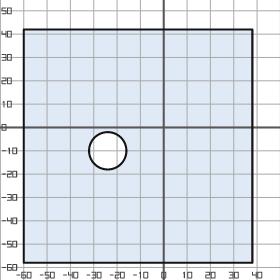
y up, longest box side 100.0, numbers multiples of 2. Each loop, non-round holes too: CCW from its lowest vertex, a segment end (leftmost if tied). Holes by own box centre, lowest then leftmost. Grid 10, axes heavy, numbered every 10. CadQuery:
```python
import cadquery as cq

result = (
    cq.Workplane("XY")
    .moveTo(-60.0, -58.0)
    .lineTo(38.0, -58.0)
    .lineTo(38.0, 42.0)
    .lineTo(-60.0, 42.0)
    .close()
    .moveTo(-24.0, -10.0)
    .circle(8.0)
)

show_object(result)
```